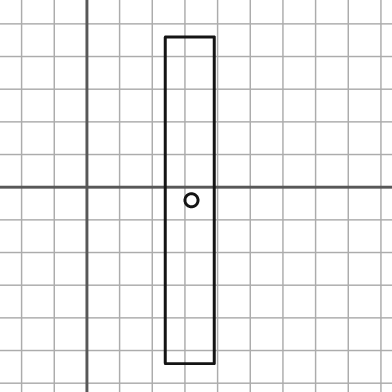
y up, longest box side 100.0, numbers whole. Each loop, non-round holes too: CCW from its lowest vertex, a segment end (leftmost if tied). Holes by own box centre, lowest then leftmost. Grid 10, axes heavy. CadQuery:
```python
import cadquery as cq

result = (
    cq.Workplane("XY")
    .moveTo(24.0, -54.0)
    .lineTo(39.0, -54.0)
    .lineTo(39.0, 46.0)
    .lineTo(24.0, 46.0)
    .close()
    .moveTo(32.0, -4.0)
    .circle(2.0)
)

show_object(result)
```